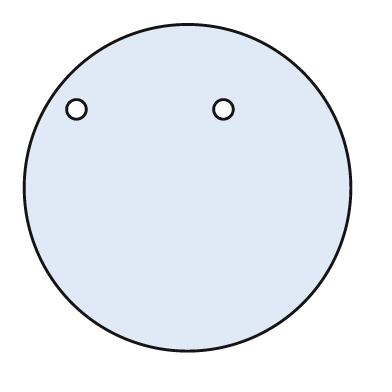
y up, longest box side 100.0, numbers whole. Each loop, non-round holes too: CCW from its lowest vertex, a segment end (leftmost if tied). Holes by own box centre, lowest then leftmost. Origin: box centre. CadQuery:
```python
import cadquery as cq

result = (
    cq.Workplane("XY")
    .moveTo(0.0, 0.0)
    .circle(50.0)
    .moveTo(-34.0, 24.0)
    .circle(3.0)
    .moveTo(11.0, 24.0)
    .circle(3.0)
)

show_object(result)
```